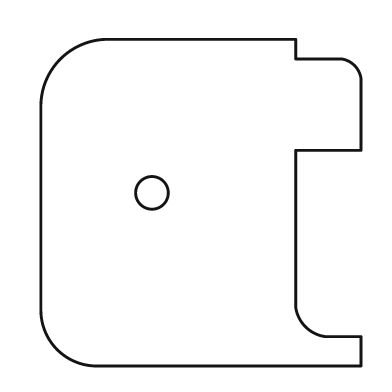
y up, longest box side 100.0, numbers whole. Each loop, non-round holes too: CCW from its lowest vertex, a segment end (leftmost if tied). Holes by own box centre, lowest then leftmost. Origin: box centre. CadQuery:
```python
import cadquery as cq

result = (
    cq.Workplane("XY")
    .moveTo(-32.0, -50.0)
    .lineTo(49.0, -50.0)
    .lineTo(49.0, -41.0)
    .lineTo(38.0, -41.0)
    .threePointArc((32.0, -38.0), (29.0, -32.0))
    .lineTo(29.0, 16.0)
    .lineTo(49.0, 16.0)
    .lineTo(49.0, 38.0)
    .threePointArc((47.0, 42.0), (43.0, 44.0))
    .lineTo(29.0, 44.0)
    .lineTo(29.0, 50.0)
    .lineTo(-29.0, 50.0)
    .threePointArc((-43.0, 44.0), (-49.0, 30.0))
    .lineTo(-49.0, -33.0)
    .threePointArc((-44.0, -45.0), (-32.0, -50.0))
    .close()
    .moveTo(-15.0, 3.0)
    .circle(5.0)
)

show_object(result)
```